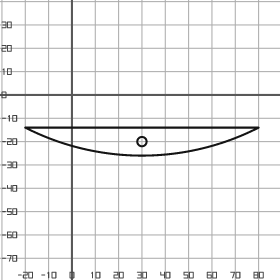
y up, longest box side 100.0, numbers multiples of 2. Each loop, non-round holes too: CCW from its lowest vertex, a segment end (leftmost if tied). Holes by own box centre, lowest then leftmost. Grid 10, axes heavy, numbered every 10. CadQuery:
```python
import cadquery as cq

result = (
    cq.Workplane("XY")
    .moveTo(-20.0, -14.0)
    .threePointArc((30.0, -26.0), (80.0, -14.0))
    .close()
    .moveTo(30.0, -20.0)
    .circle(2.0)
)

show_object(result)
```